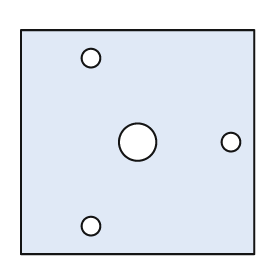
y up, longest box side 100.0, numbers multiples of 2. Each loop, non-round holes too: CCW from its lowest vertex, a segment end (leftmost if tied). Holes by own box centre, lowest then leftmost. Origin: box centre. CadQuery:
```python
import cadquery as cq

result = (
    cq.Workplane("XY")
    .moveTo(-50.0, -48.0)
    .lineTo(50.0, -48.0)
    .lineTo(50.0, 48.0)
    .lineTo(-50.0, 48.0)
    .close()
    .moveTo(-20.0, -36.0)
    .circle(4.0)
    .moveTo(0.0, 0.0)
    .circle(8.0)
    .moveTo(40.0, 0.0)
    .circle(4.0)
    .moveTo(-20.0, 36.0)
    .circle(4.0)
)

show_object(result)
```